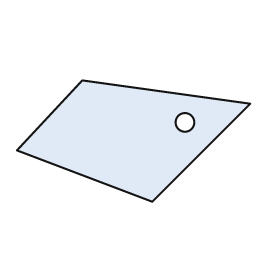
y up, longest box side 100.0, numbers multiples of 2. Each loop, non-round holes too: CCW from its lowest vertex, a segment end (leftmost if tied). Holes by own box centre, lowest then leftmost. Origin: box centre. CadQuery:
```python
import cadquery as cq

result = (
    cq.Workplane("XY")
    .moveTo(8.0, -26.0)
    .lineTo(50.0, 16.0)
    .lineTo(-22.0, 26.0)
    .lineTo(-50.0, -4.0)
    .close()
    .moveTo(22.0, 8.0)
    .circle(4.0)
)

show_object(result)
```